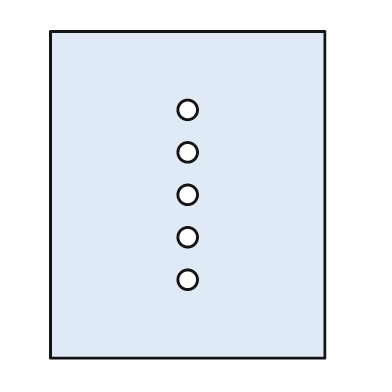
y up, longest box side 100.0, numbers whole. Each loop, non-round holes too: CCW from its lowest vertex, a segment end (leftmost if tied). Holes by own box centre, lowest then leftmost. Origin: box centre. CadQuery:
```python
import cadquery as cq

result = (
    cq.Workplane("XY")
    .moveTo(-42.0, -50.0)
    .lineTo(42.0, -50.0)
    .lineTo(42.0, 50.0)
    .lineTo(-42.0, 50.0)
    .close()
    .moveTo(0.0, -26.0)
    .circle(3.0)
    .moveTo(0.0, -13.0)
    .circle(3.0)
    .moveTo(0.0, 0.0)
    .circle(3.0)
    .moveTo(0.0, 13.0)
    .circle(3.0)
    .moveTo(0.0, 26.0)
    .circle(3.0)
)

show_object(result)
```